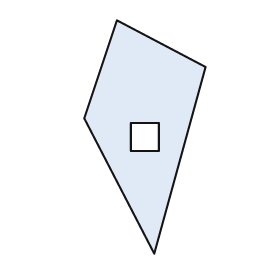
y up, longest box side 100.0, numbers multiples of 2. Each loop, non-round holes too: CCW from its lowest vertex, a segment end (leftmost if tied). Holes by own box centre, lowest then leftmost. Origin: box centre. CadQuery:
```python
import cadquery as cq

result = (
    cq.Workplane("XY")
    .moveTo(4.0, -50.0)
    .lineTo(26.0, 30.0)
    .lineTo(-12.0, 50.0)
    .lineTo(-26.0, 8.0)
    .close()
    .moveTo(-6.0, -6.0)
    .lineTo(6.0, -6.0)
    .lineTo(6.0, 6.0)
    .lineTo(-6.0, 6.0)
    .close()
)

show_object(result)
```